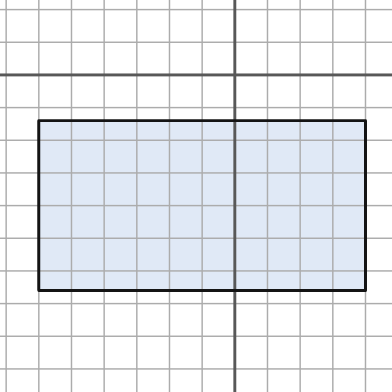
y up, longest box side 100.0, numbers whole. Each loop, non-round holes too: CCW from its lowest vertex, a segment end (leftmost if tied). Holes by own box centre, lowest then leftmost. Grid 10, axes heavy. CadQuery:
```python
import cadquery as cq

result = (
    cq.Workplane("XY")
    .moveTo(-60.0, -66.0)
    .lineTo(40.0, -66.0)
    .lineTo(40.0, -14.0)
    .lineTo(-60.0, -14.0)
    .close()
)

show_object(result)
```